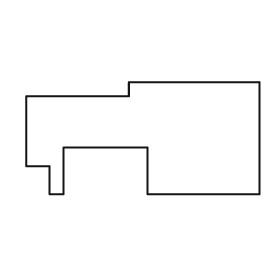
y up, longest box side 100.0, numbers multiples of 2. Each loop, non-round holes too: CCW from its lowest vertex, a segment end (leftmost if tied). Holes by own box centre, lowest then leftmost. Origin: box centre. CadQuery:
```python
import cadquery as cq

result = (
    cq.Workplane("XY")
    .moveTo(-40.0, -24.0)
    .lineTo(-34.0, -24.0)
    .lineTo(-34.0, -4.0)
    .lineTo(2.0, -4.0)
    .lineTo(2.0, -24.0)
    .lineTo(50.0, -24.0)
    .lineTo(50.0, 24.0)
    .lineTo(-6.0, 24.0)
    .lineTo(-6.0, 18.0)
    .lineTo(-50.0, 18.0)
    .lineTo(-50.0, -12.0)
    .lineTo(-40.0, -12.0)
    .close()
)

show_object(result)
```